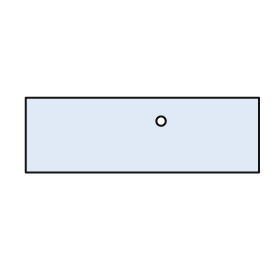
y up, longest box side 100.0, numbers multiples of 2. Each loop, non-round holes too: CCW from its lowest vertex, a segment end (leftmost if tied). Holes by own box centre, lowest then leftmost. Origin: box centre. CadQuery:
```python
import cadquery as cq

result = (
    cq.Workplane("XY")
    .moveTo(-50.0, -16.0)
    .lineTo(50.0, -16.0)
    .lineTo(50.0, 16.0)
    .lineTo(-50.0, 16.0)
    .close()
    .moveTo(8.0, 6.0)
    .circle(2.0)
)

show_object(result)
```